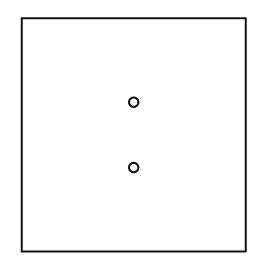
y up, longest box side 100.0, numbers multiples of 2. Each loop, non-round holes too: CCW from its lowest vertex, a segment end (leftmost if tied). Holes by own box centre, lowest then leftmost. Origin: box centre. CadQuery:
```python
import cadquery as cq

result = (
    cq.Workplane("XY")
    .moveTo(-48.0, -50.0)
    .lineTo(48.0, -50.0)
    .lineTo(48.0, 50.0)
    .lineTo(-48.0, 50.0)
    .close()
    .moveTo(0.0, -14.0)
    .circle(2.0)
    .moveTo(0.0, 14.0)
    .circle(2.0)
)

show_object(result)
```